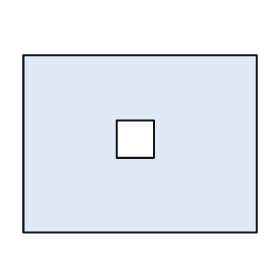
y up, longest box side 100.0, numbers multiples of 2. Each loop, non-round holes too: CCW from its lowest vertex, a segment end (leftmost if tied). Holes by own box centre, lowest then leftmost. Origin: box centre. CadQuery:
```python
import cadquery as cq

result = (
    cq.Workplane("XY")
    .moveTo(-50.0, -38.0)
    .lineTo(50.0, -38.0)
    .lineTo(50.0, 38.0)
    .lineTo(-50.0, 38.0)
    .close()
    .moveTo(-10.0, -6.0)
    .lineTo(6.0, -6.0)
    .lineTo(6.0, 10.0)
    .lineTo(-10.0, 10.0)
    .close()
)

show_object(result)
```